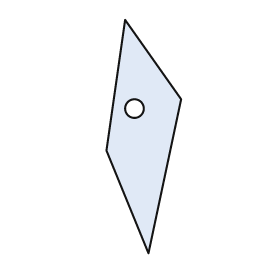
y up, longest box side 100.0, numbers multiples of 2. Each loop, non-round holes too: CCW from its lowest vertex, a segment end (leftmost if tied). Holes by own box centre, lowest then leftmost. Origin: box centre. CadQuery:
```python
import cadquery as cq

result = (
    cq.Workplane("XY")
    .moveTo(2.0, -50.0)
    .lineTo(16.0, 16.0)
    .lineTo(-8.0, 50.0)
    .lineTo(-16.0, -6.0)
    .close()
    .moveTo(-4.0, 12.0)
    .circle(4.0)
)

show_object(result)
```